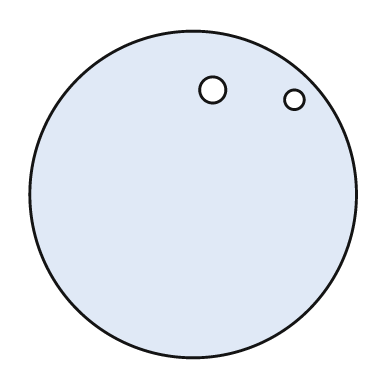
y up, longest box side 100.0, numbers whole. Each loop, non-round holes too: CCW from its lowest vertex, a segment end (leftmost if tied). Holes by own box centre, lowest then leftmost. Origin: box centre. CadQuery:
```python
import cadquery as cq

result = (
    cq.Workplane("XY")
    .moveTo(0.0, 0.0)
    .circle(50.0)
    .moveTo(31.0, 29.0)
    .circle(3.0)
    .moveTo(6.0, 32.0)
    .circle(4.0)
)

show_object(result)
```